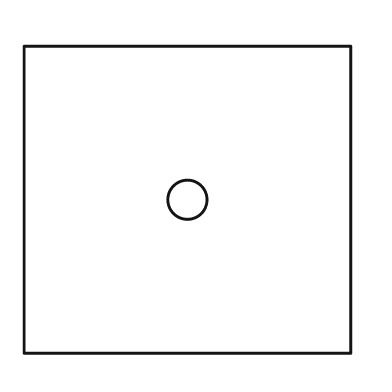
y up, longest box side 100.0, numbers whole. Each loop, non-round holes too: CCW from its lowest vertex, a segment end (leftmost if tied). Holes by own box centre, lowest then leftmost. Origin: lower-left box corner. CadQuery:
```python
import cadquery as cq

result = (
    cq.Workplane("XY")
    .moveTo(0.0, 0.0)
    .lineTo(100.0, 0.0)
    .lineTo(100.0, 94.0)
    .lineTo(0.0, 94.0)
    .close()
    .moveTo(50.0, 47.0)
    .circle(6.0)
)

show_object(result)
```